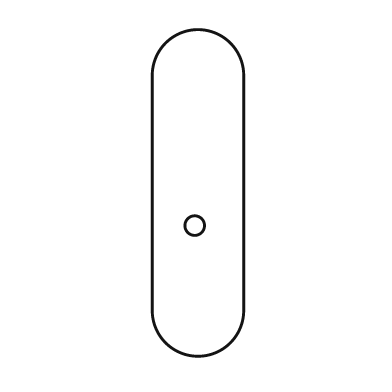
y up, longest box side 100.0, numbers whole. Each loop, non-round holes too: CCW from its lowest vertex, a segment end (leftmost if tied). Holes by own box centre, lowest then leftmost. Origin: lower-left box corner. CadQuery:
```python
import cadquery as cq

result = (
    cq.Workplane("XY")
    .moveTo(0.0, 14.0)
    .threePointArc((14.0, 0.0), (28.0, 14.0))
    .lineTo(28.0, 86.0)
    .threePointArc((14.0, 100.0), (0.0, 86.0))
    .close()
    .moveTo(13.0, 40.0)
    .circle(3.0)
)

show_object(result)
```